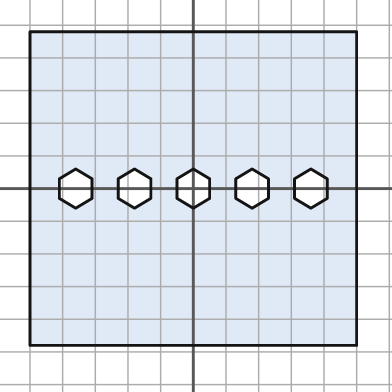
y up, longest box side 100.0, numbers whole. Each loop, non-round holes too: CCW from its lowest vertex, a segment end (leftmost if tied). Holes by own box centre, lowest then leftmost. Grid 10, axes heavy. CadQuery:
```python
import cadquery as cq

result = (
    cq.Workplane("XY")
    .moveTo(-50.0, -48.0)
    .lineTo(50.0, -48.0)
    .lineTo(50.0, 48.0)
    .lineTo(-50.0, 48.0)
    .close()
    .moveTo(-36.0, -6.0)
    .lineTo(-31.0, -3.0)
    .lineTo(-31.0, 3.0)
    .lineTo(-36.0, 6.0)
    .lineTo(-41.0, 3.0)
    .lineTo(-41.0, -3.0)
    .close()
    .moveTo(-18.0, -6.0)
    .lineTo(-13.0, -3.0)
    .lineTo(-13.0, 3.0)
    .lineTo(-18.0, 6.0)
    .lineTo(-23.0, 3.0)
    .lineTo(-23.0, -3.0)
    .close()
    .moveTo(0.0, -6.0)
    .lineTo(5.0, -3.0)
    .lineTo(5.0, 3.0)
    .lineTo(0.0, 6.0)
    .lineTo(-5.0, 3.0)
    .lineTo(-5.0, -3.0)
    .close()
    .moveTo(18.0, -6.0)
    .lineTo(23.0, -3.0)
    .lineTo(23.0, 3.0)
    .lineTo(18.0, 6.0)
    .lineTo(13.0, 3.0)
    .lineTo(13.0, -3.0)
    .close()
    .moveTo(36.0, -6.0)
    .lineTo(41.0, -3.0)
    .lineTo(41.0, 3.0)
    .lineTo(36.0, 6.0)
    .lineTo(31.0, 3.0)
    .lineTo(31.0, -3.0)
    .close()
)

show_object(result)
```